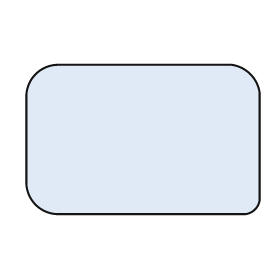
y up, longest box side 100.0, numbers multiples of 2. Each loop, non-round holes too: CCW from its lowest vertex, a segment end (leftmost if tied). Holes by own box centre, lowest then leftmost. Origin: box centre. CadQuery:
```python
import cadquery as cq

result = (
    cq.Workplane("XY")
    .moveTo(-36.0, -32.0)
    .lineTo(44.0, -32.0)
    .threePointArc((48.0, -30.0), (50.0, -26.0))
    .lineTo(50.0, 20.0)
    .threePointArc((46.0, 28.0), (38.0, 32.0))
    .lineTo(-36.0, 32.0)
    .threePointArc((-46.0, 28.0), (-50.0, 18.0))
    .lineTo(-50.0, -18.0)
    .threePointArc((-46.0, -28.0), (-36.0, -32.0))
    .close()
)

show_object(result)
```